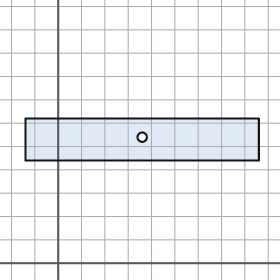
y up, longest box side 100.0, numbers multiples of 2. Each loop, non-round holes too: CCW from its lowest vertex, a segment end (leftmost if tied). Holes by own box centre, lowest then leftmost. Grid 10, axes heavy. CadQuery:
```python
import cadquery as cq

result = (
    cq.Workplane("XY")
    .moveTo(-14.0, 44.0)
    .lineTo(86.0, 44.0)
    .lineTo(86.0, 62.0)
    .lineTo(-14.0, 62.0)
    .close()
    .moveTo(36.0, 54.0)
    .circle(2.0)
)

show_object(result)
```